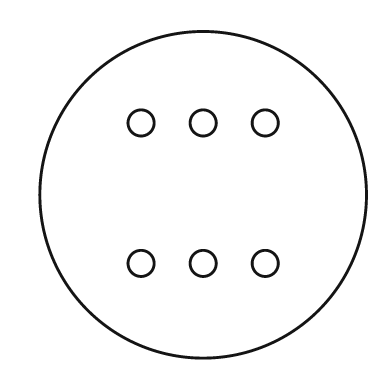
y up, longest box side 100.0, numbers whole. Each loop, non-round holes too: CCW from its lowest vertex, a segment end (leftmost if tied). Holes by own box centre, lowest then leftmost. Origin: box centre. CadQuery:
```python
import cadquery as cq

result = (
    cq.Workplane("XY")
    .moveTo(0.0, 0.0)
    .circle(50.0)
    .moveTo(-19.0, -21.0)
    .circle(4.0)
    .moveTo(0.0, -21.0)
    .circle(4.0)
    .moveTo(19.0, -21.0)
    .circle(4.0)
    .moveTo(-19.0, 22.0)
    .circle(4.0)
    .moveTo(0.0, 22.0)
    .circle(4.0)
    .moveTo(19.0, 22.0)
    .circle(4.0)
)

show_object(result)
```